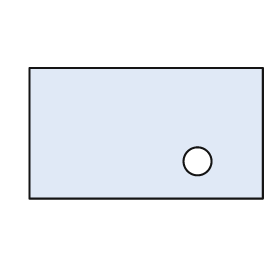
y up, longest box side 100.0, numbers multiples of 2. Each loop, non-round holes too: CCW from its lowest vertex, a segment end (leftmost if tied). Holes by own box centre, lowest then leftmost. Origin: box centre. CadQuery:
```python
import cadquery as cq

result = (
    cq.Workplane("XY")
    .moveTo(-50.0, -28.0)
    .lineTo(50.0, -28.0)
    .lineTo(50.0, 28.0)
    .lineTo(-50.0, 28.0)
    .close()
    .moveTo(22.0, -12.0)
    .circle(6.0)
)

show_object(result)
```